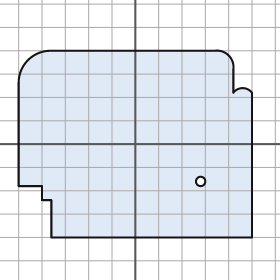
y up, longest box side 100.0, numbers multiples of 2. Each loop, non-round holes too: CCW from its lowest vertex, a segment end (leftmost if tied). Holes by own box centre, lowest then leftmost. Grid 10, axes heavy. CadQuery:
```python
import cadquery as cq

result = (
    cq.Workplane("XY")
    .moveTo(-36.0, -40.0)
    .lineTo(50.0, -40.0)
    .lineTo(50.0, 22.0)
    .threePointArc((46.0, 24.0), (42.0, 22.0))
    .lineTo(42.0, 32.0)
    .threePointArc((40.0, 38.0), (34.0, 40.0))
    .lineTo(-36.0, 40.0)
    .threePointArc((-46.0, 36.0), (-50.0, 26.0))
    .lineTo(-50.0, -18.0)
    .lineTo(-40.0, -18.0)
    .lineTo(-40.0, -24.0)
    .lineTo(-36.0, -24.0)
    .close()
    .moveTo(28.0, -16.0)
    .circle(2.0)
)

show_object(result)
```